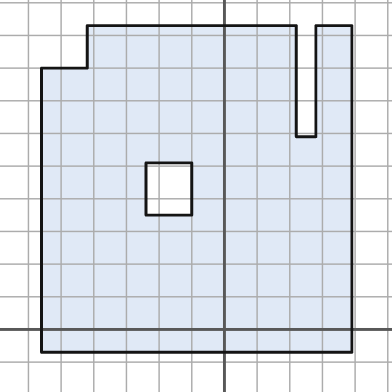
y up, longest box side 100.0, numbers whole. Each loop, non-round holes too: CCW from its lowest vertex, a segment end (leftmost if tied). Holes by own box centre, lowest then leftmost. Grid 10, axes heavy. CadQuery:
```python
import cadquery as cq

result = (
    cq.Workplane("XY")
    .moveTo(-56.0, -7.0)
    .lineTo(39.0, -7.0)
    .lineTo(39.0, 93.0)
    .lineTo(28.0, 93.0)
    .lineTo(28.0, 59.0)
    .lineTo(22.0, 59.0)
    .lineTo(22.0, 93.0)
    .lineTo(-42.0, 93.0)
    .lineTo(-42.0, 80.0)
    .lineTo(-56.0, 80.0)
    .close()
    .moveTo(-24.0, 35.0)
    .lineTo(-10.0, 35.0)
    .lineTo(-10.0, 51.0)
    .lineTo(-24.0, 51.0)
    .close()
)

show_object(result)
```